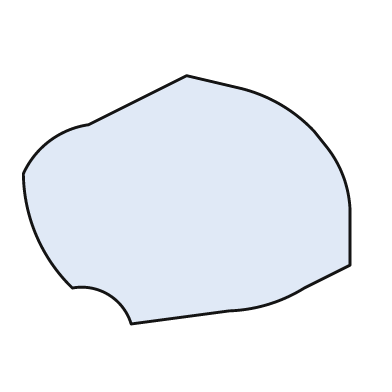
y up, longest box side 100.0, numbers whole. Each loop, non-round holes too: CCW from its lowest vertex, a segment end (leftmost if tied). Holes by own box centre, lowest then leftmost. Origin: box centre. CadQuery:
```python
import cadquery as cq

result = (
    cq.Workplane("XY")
    .moveTo(-17.0, -38.0)
    .lineTo(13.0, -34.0)
    .threePointArc((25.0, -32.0), (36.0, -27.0))
    .lineTo(50.0, -20.0)
    .lineTo(50.0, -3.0)
    .threePointArc((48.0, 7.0), (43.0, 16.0))
    .lineTo(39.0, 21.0)
    .threePointArc((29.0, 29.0), (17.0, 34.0))
    .lineTo(0.0, 38.0)
    .lineTo(-30.0, 23.0)
    .threePointArc((-42.0, 18.0), (-50.0, 8.0))
    .threePointArc((-46.0, -11.0), (-35.0, -27.0))
    .threePointArc((-24.0, -29.0), (-17.0, -38.0))
    .close()
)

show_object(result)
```